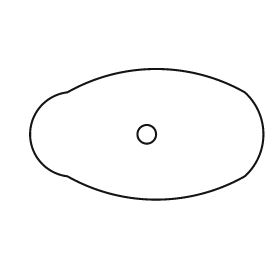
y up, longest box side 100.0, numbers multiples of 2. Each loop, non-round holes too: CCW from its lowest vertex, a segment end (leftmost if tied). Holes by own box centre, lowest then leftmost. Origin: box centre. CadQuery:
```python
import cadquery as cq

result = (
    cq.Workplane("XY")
    .moveTo(-34.0, -18.0)
    .threePointArc((4.0, -28.0), (42.0, -18.0))
    .threePointArc((50.0, 0.0), (42.0, 18.0))
    .threePointArc((4.0, 28.0), (-34.0, 18.0))
    .threePointArc((-50.0, 0.0), (-34.0, -18.0))
    .close()
    .moveTo(0.0, 0.0)
    .circle(4.0)
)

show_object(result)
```